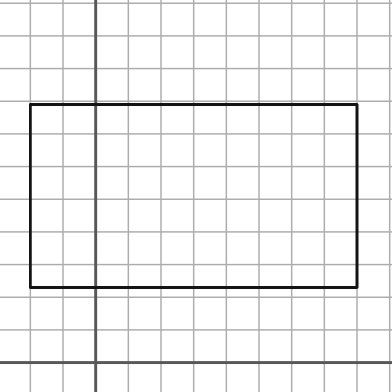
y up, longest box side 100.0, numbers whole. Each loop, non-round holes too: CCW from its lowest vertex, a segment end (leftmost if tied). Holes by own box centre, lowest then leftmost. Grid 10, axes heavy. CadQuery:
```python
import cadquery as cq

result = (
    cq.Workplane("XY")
    .moveTo(-20.0, 23.0)
    .lineTo(80.0, 23.0)
    .lineTo(80.0, 79.0)
    .lineTo(-20.0, 79.0)
    .close()
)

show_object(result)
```